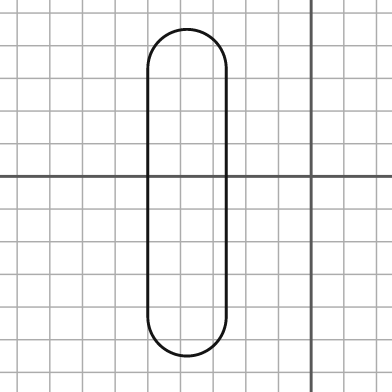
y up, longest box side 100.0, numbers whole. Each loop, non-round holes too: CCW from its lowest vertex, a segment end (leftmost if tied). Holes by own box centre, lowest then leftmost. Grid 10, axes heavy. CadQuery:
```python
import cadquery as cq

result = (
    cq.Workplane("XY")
    .moveTo(-50.0, -43.0)
    .threePointArc((-38.0, -55.0), (-26.0, -43.0))
    .lineTo(-26.0, 33.0)
    .threePointArc((-38.0, 45.0), (-50.0, 33.0))
    .close()
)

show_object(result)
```